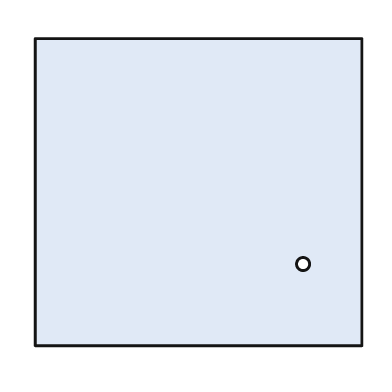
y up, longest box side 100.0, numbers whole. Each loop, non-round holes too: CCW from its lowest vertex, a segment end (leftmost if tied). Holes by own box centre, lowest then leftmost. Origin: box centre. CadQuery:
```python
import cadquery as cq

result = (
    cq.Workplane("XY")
    .moveTo(-50.0, -47.0)
    .lineTo(50.0, -47.0)
    .lineTo(50.0, 47.0)
    .lineTo(-50.0, 47.0)
    .close()
    .moveTo(32.0, -22.0)
    .circle(2.0)
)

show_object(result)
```